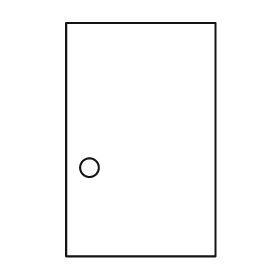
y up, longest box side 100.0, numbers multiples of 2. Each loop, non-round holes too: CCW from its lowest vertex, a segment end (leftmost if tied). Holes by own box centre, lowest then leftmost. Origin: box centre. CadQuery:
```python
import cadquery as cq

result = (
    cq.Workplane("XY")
    .moveTo(-32.0, -50.0)
    .lineTo(32.0, -50.0)
    .lineTo(32.0, 50.0)
    .lineTo(-32.0, 50.0)
    .close()
    .moveTo(-22.0, -12.0)
    .circle(4.0)
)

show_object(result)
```